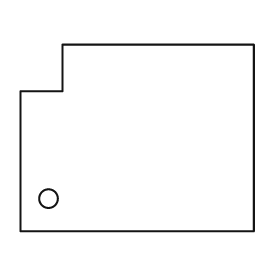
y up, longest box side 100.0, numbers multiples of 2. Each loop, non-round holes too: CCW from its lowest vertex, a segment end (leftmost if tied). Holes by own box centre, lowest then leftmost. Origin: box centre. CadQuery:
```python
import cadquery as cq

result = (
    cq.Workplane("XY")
    .moveTo(-50.0, -40.0)
    .lineTo(50.0, -40.0)
    .lineTo(50.0, 40.0)
    .lineTo(-32.0, 40.0)
    .lineTo(-32.0, 20.0)
    .lineTo(-50.0, 20.0)
    .close()
    .moveTo(-38.0, -26.0)
    .circle(4.0)
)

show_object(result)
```